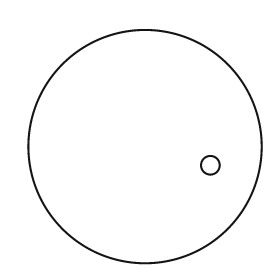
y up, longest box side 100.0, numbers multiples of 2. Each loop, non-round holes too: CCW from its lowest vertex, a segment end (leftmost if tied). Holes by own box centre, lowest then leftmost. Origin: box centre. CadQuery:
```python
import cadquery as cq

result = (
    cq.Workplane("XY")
    .moveTo(0.0, 0.0)
    .circle(50.0)
    .moveTo(28.0, -8.0)
    .circle(4.0)
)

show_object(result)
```